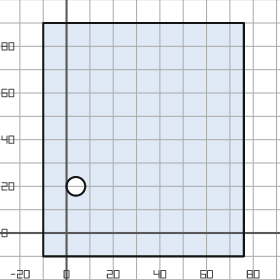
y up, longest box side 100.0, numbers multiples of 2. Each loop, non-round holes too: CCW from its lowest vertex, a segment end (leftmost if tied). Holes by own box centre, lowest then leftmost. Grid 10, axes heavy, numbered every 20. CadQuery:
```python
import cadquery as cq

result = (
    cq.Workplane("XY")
    .moveTo(-10.0, -10.0)
    .lineTo(76.0, -10.0)
    .lineTo(76.0, 90.0)
    .lineTo(-10.0, 90.0)
    .close()
    .moveTo(4.0, 20.0)
    .circle(4.0)
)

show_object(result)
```